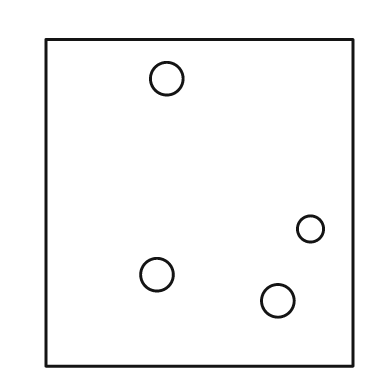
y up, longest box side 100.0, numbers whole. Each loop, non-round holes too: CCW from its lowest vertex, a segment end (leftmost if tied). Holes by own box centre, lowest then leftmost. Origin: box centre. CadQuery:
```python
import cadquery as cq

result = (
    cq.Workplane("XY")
    .moveTo(-47.0, -50.0)
    .lineTo(47.0, -50.0)
    .lineTo(47.0, 50.0)
    .lineTo(-47.0, 50.0)
    .close()
    .moveTo(24.0, -30.0)
    .circle(5.0)
    .moveTo(-13.0, -22.0)
    .circle(5.0)
    .moveTo(34.0, -8.0)
    .circle(4.0)
    .moveTo(-10.0, 38.0)
    .circle(5.0)
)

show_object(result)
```